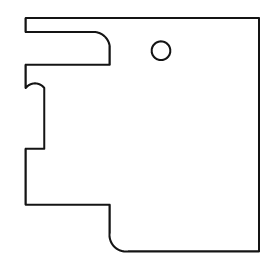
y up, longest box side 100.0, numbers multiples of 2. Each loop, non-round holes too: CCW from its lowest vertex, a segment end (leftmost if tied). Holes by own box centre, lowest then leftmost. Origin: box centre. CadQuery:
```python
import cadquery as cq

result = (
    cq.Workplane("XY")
    .moveTo(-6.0, -50.0)
    .lineTo(50.0, -50.0)
    .lineTo(50.0, 50.0)
    .lineTo(-50.0, 50.0)
    .lineTo(-50.0, 44.0)
    .lineTo(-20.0, 44.0)
    .threePointArc((-16.0, 42.0), (-14.0, 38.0))
    .lineTo(-14.0, 30.0)
    .lineTo(-50.0, 30.0)
    .lineTo(-50.0, 20.0)
    .threePointArc((-46.0, 22.0), (-42.0, 20.0))
    .lineTo(-42.0, -6.0)
    .lineTo(-50.0, -6.0)
    .lineTo(-50.0, -30.0)
    .lineTo(-14.0, -30.0)
    .lineTo(-14.0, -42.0)
    .threePointArc((-12.0, -48.0), (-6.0, -50.0))
    .close()
    .moveTo(8.0, 36.0)
    .circle(4.0)
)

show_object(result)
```